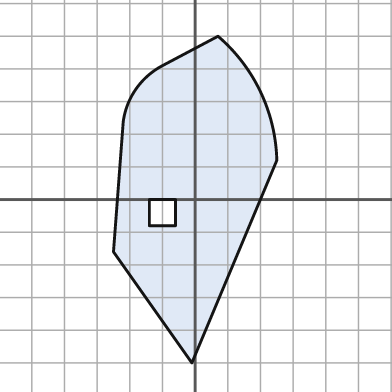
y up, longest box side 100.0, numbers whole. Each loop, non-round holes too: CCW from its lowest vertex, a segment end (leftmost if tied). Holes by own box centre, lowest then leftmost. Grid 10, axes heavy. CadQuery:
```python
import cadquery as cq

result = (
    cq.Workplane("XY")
    .moveTo(-1.0, -50.0)
    .lineTo(25.0, 12.0)
    .threePointArc((20.0, 33.0), (7.0, 50.0))
    .lineTo(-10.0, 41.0)
    .threePointArc((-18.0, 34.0), (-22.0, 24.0))
    .lineTo(-25.0, -16.0)
    .close()
    .moveTo(-14.0, -8.0)
    .lineTo(-6.0, -8.0)
    .lineTo(-6.0, 0.0)
    .lineTo(-14.0, 0.0)
    .close()
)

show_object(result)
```